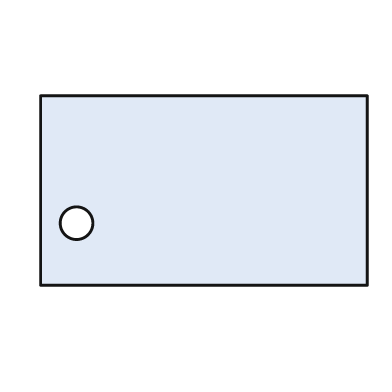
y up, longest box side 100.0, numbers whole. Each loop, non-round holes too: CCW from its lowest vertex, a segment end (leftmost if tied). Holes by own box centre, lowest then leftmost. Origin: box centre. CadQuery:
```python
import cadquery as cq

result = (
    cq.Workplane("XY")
    .moveTo(-50.0, -29.0)
    .lineTo(50.0, -29.0)
    .lineTo(50.0, 29.0)
    .lineTo(-50.0, 29.0)
    .close()
    .moveTo(-39.0, -10.0)
    .circle(5.0)
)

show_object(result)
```